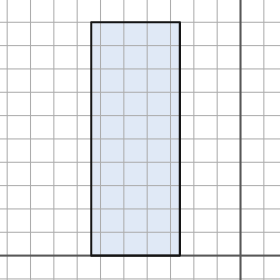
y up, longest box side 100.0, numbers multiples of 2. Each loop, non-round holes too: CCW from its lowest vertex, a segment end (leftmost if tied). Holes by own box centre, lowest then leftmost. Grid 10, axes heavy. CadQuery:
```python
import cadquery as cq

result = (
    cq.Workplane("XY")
    .moveTo(-64.0, 0.0)
    .lineTo(-26.0, 0.0)
    .lineTo(-26.0, 100.0)
    .lineTo(-64.0, 100.0)
    .close()
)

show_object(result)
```